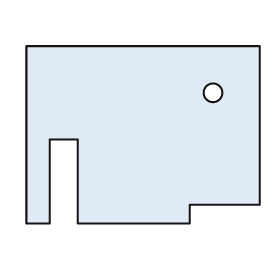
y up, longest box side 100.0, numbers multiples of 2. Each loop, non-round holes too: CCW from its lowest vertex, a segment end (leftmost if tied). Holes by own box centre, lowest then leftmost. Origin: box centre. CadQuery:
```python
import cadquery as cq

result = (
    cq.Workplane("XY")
    .moveTo(-50.0, -38.0)
    .lineTo(-40.0, -38.0)
    .lineTo(-40.0, -2.0)
    .lineTo(-28.0, -2.0)
    .lineTo(-28.0, -38.0)
    .lineTo(20.0, -38.0)
    .lineTo(20.0, -30.0)
    .lineTo(50.0, -30.0)
    .lineTo(50.0, 38.0)
    .lineTo(-50.0, 38.0)
    .close()
    .moveTo(30.0, 18.0)
    .circle(4.0)
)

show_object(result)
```